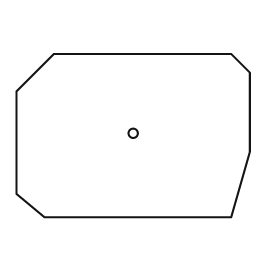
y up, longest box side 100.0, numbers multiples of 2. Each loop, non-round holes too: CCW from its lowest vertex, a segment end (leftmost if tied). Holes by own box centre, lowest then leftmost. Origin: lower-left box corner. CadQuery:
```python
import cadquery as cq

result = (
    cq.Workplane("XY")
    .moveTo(12.0, 0.0)
    .lineTo(92.0, 0.0)
    .lineTo(100.0, 28.0)
    .lineTo(100.0, 62.0)
    .lineTo(92.0, 70.0)
    .lineTo(16.0, 70.0)
    .lineTo(0.0, 54.0)
    .lineTo(0.0, 10.0)
    .close()
    .moveTo(50.0, 36.0)
    .circle(2.0)
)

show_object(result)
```